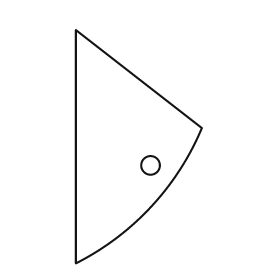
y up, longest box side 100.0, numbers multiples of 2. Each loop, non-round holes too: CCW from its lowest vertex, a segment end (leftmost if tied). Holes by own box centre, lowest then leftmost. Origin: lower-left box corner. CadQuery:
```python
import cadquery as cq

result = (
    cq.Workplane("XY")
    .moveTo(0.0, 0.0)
    .threePointArc((32.0, 24.0), (54.0, 58.0))
    .lineTo(0.0, 100.0)
    .close()
    .moveTo(32.0, 42.0)
    .circle(4.0)
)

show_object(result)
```